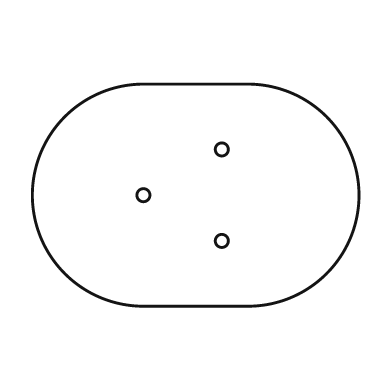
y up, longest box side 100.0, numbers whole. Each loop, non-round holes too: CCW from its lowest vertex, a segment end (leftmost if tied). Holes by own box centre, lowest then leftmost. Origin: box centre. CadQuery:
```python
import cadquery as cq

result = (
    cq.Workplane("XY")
    .moveTo(-16.0, -34.0)
    .lineTo(16.0, -34.0)
    .threePointArc((50.0, 0.0), (16.0, 34.0))
    .lineTo(-16.0, 34.0)
    .threePointArc((-50.0, 0.0), (-16.0, -34.0))
    .close()
    .moveTo(8.0, -14.0)
    .circle(2.0)
    .moveTo(-16.0, 0.0)
    .circle(2.0)
    .moveTo(8.0, 14.0)
    .circle(2.0)
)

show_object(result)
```